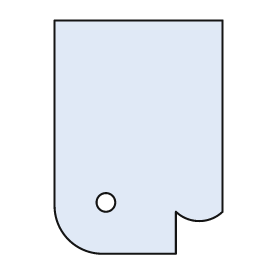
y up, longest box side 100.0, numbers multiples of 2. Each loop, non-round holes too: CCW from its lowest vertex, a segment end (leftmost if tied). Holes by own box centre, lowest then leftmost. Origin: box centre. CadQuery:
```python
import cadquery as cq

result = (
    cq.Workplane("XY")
    .moveTo(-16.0, -50.0)
    .lineTo(16.0, -50.0)
    .lineTo(16.0, -32.0)
    .threePointArc((26.0, -36.0), (36.0, -32.0))
    .lineTo(36.0, 50.0)
    .lineTo(-36.0, 50.0)
    .lineTo(-36.0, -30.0)
    .threePointArc((-30.0, -44.0), (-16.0, -50.0))
    .close()
    .moveTo(-14.0, -28.0)
    .circle(4.0)
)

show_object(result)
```